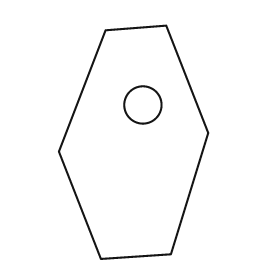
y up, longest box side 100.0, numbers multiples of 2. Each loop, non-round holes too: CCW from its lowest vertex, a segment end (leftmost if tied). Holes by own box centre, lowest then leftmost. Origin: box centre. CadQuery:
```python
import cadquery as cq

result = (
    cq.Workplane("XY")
    .moveTo(-14.0, -50.0)
    .lineTo(16.0, -48.0)
    .lineTo(32.0, 4.0)
    .lineTo(14.0, 50.0)
    .lineTo(-12.0, 48.0)
    .lineTo(-32.0, -4.0)
    .close()
    .moveTo(4.0, 16.0)
    .circle(8.0)
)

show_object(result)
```